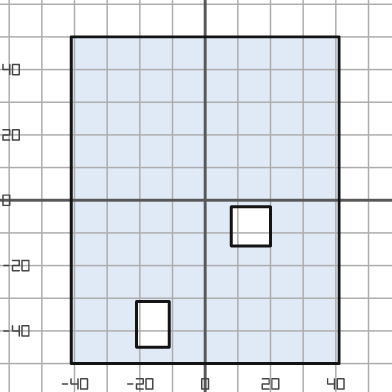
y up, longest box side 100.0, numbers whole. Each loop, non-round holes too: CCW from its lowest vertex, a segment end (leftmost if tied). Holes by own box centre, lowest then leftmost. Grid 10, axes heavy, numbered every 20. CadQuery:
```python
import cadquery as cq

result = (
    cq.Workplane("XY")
    .moveTo(-41.0, -50.0)
    .lineTo(41.0, -50.0)
    .lineTo(41.0, 50.0)
    .lineTo(-41.0, 50.0)
    .close()
    .moveTo(-21.0, -45.0)
    .lineTo(-11.0, -45.0)
    .lineTo(-11.0, -31.0)
    .lineTo(-21.0, -31.0)
    .close()
    .moveTo(8.0, -14.0)
    .lineTo(20.0, -14.0)
    .lineTo(20.0, -2.0)
    .lineTo(8.0, -2.0)
    .close()
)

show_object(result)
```